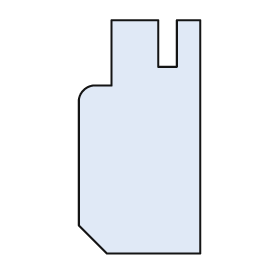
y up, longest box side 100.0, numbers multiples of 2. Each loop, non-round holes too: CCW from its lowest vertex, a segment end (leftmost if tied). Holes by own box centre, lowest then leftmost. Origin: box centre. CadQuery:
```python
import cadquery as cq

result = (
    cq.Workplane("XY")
    .moveTo(-14.0, -50.0)
    .lineTo(26.0, -50.0)
    .lineTo(26.0, 50.0)
    .lineTo(16.0, 50.0)
    .lineTo(16.0, 30.0)
    .lineTo(8.0, 30.0)
    .lineTo(8.0, 50.0)
    .lineTo(-12.0, 50.0)
    .lineTo(-12.0, 22.0)
    .lineTo(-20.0, 22.0)
    .threePointArc((-24.0, 20.0), (-26.0, 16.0))
    .lineTo(-26.0, -38.0)
    .close()
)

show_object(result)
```